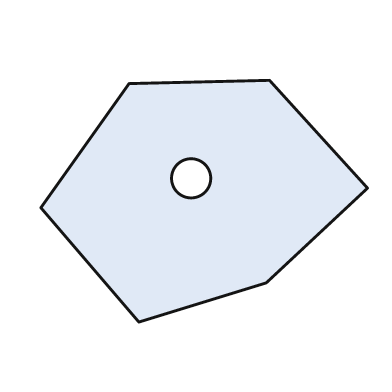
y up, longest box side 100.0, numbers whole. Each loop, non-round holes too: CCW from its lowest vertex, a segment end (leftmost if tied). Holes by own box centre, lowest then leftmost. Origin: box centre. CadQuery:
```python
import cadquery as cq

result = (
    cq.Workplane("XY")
    .moveTo(-20.0, -37.0)
    .lineTo(19.0, -25.0)
    .lineTo(50.0, 4.0)
    .lineTo(20.0, 37.0)
    .lineTo(-23.0, 36.0)
    .lineTo(-50.0, -2.0)
    .close()
    .moveTo(-4.0, 7.0)
    .circle(6.0)
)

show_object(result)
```